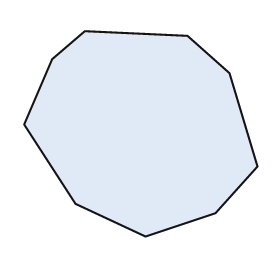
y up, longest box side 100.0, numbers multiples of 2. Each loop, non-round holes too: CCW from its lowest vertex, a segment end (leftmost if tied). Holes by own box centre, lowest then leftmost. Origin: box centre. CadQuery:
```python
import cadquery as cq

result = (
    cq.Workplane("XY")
    .moveTo(2.0, -44.0)
    .lineTo(32.0, -34.0)
    .lineTo(50.0, -14.0)
    .lineTo(38.0, 26.0)
    .lineTo(20.0, 42.0)
    .lineTo(-24.0, 44.0)
    .lineTo(-38.0, 32.0)
    .lineTo(-50.0, 4.0)
    .lineTo(-28.0, -30.0)
    .close()
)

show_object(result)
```